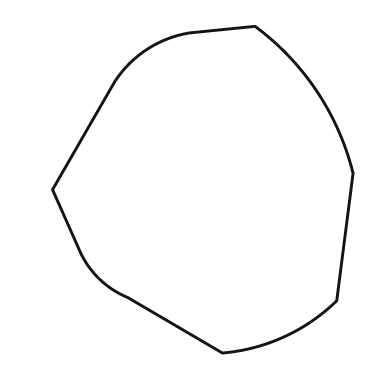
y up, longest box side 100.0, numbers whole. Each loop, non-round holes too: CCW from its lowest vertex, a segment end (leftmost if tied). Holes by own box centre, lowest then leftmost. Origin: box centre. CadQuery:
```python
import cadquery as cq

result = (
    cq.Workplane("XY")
    .moveTo(6.0, -50.0)
    .threePointArc((25.0, -45.0), (41.0, -34.0))
    .lineTo(46.0, 5.0)
    .threePointArc((35.0, 30.0), (16.0, 50.0))
    .lineTo(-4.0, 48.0)
    .threePointArc((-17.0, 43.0), (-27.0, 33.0))
    .lineTo(-46.0, 0.0)
    .lineTo(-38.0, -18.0)
    .threePointArc((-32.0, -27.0), (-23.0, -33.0))
    .close()
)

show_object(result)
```